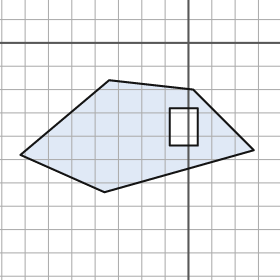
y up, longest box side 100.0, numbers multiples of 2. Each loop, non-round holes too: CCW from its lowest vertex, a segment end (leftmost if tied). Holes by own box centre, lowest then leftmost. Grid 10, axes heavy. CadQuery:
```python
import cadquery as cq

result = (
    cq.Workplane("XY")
    .moveTo(-36.0, -64.0)
    .lineTo(28.0, -46.0)
    .lineTo(2.0, -20.0)
    .lineTo(-34.0, -16.0)
    .lineTo(-72.0, -48.0)
    .close()
    .moveTo(-8.0, -44.0)
    .lineTo(4.0, -44.0)
    .lineTo(4.0, -28.0)
    .lineTo(-8.0, -28.0)
    .close()
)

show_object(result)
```